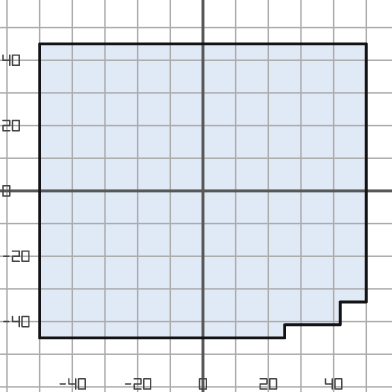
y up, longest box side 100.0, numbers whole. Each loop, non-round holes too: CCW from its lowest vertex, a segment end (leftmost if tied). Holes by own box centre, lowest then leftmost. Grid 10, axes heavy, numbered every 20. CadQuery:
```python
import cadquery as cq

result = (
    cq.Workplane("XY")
    .moveTo(-50.0, -45.0)
    .lineTo(25.0, -45.0)
    .lineTo(25.0, -41.0)
    .lineTo(42.0, -41.0)
    .lineTo(42.0, -34.0)
    .lineTo(50.0, -34.0)
    .lineTo(50.0, 45.0)
    .lineTo(-50.0, 45.0)
    .close()
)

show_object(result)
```